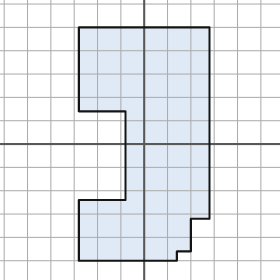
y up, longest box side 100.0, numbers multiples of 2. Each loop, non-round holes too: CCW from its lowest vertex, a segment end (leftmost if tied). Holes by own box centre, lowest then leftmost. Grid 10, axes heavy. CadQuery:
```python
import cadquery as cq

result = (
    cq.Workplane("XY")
    .moveTo(-28.0, -50.0)
    .lineTo(14.0, -50.0)
    .lineTo(14.0, -46.0)
    .lineTo(20.0, -46.0)
    .lineTo(20.0, -32.0)
    .lineTo(28.0, -32.0)
    .lineTo(28.0, 50.0)
    .lineTo(-28.0, 50.0)
    .lineTo(-28.0, 14.0)
    .lineTo(-8.0, 14.0)
    .lineTo(-8.0, -24.0)
    .lineTo(-28.0, -24.0)
    .close()
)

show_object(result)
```